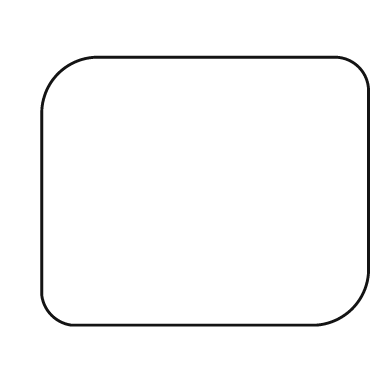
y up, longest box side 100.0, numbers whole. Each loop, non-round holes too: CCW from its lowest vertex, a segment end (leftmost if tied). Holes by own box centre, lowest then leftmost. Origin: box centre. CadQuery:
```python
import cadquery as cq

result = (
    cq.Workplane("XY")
    .moveTo(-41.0, -41.0)
    .lineTo(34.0, -41.0)
    .threePointArc((45.0, -36.0), (50.0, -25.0))
    .lineTo(50.0, 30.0)
    .threePointArc((47.0, 38.0), (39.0, 41.0))
    .lineTo(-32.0, 41.0)
    .threePointArc((-45.0, 36.0), (-50.0, 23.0))
    .lineTo(-50.0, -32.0)
    .threePointArc((-47.0, -38.0), (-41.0, -41.0))
    .close()
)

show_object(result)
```